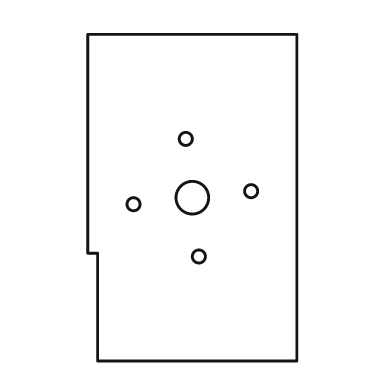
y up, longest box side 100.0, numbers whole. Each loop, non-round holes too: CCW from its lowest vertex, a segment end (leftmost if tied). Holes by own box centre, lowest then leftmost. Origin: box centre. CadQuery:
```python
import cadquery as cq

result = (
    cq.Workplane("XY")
    .moveTo(-29.0, -50.0)
    .lineTo(32.0, -50.0)
    .lineTo(32.0, 50.0)
    .lineTo(-32.0, 50.0)
    .lineTo(-32.0, -17.0)
    .lineTo(-29.0, -17.0)
    .close()
    .moveTo(2.0, -18.0)
    .circle(2.0)
    .moveTo(-18.0, -2.0)
    .circle(2.0)
    .moveTo(0.0, 0.0)
    .circle(5.0)
    .moveTo(18.0, 2.0)
    .circle(2.0)
    .moveTo(-2.0, 18.0)
    .circle(2.0)
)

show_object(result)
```